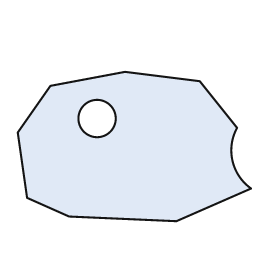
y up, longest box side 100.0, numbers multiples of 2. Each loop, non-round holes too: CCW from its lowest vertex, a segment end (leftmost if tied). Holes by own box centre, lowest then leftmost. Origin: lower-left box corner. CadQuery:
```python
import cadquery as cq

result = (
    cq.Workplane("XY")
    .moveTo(68.0, 0.0)
    .lineTo(100.0, 14.0)
    .threePointArc((92.0, 26.0), (94.0, 40.0))
    .lineTo(78.0, 60.0)
    .lineTo(46.0, 64.0)
    .lineTo(14.0, 58.0)
    .lineTo(0.0, 38.0)
    .lineTo(4.0, 10.0)
    .lineTo(22.0, 2.0)
    .close()
    .moveTo(34.0, 44.0)
    .circle(8.0)
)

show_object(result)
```